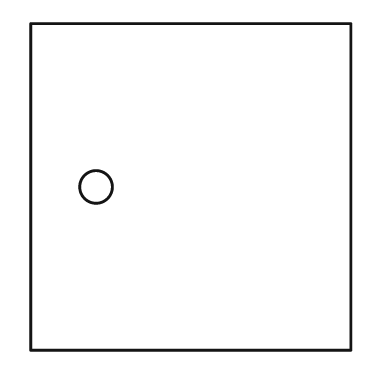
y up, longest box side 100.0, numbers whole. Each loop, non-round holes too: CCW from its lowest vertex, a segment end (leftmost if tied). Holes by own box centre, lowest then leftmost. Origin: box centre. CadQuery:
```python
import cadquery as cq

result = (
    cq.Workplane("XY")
    .moveTo(-49.0, -50.0)
    .lineTo(49.0, -50.0)
    .lineTo(49.0, 50.0)
    .lineTo(-49.0, 50.0)
    .close()
    .moveTo(-29.0, 0.0)
    .circle(5.0)
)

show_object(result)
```